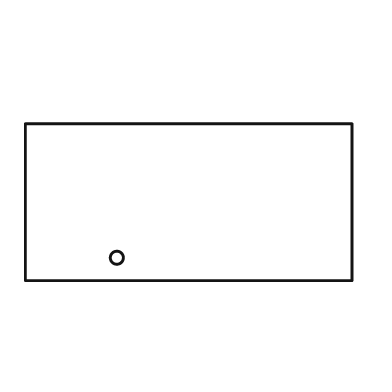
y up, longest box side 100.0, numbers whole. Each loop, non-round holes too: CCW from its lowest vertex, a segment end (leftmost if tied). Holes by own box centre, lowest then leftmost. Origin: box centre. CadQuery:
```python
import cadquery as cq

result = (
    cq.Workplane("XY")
    .moveTo(-50.0, -24.0)
    .lineTo(50.0, -24.0)
    .lineTo(50.0, 24.0)
    .lineTo(-50.0, 24.0)
    .close()
    .moveTo(-22.0, -17.0)
    .circle(2.0)
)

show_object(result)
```